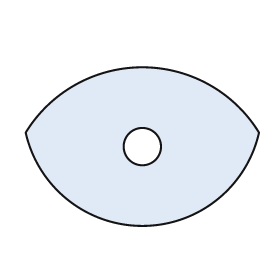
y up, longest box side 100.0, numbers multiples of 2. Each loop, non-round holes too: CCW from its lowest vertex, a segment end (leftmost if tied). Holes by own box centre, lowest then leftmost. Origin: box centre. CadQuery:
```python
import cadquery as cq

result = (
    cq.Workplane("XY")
    .moveTo(-50.0, 6.0)
    .threePointArc((0.0, -34.0), (50.0, 6.0))
    .threePointArc((0.0, 34.0), (-50.0, 6.0))
    .close()
    .moveTo(0.0, 0.0)
    .circle(8.0)
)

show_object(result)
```